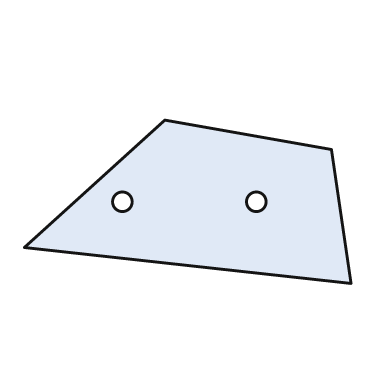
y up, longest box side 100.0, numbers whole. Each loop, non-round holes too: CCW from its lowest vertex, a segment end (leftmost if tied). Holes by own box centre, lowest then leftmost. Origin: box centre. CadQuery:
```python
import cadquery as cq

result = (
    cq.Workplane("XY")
    .moveTo(50.0, -25.0)
    .lineTo(44.0, 16.0)
    .lineTo(-7.0, 25.0)
    .lineTo(-50.0, -14.0)
    .close()
    .moveTo(-20.0, 0.0)
    .circle(3.0)
    .moveTo(21.0, 0.0)
    .circle(3.0)
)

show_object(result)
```